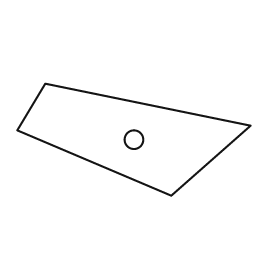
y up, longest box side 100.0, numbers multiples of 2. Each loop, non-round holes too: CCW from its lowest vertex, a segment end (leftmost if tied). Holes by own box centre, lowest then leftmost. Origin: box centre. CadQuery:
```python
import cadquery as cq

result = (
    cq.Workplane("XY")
    .moveTo(16.0, -24.0)
    .lineTo(50.0, 6.0)
    .lineTo(-38.0, 24.0)
    .lineTo(-50.0, 4.0)
    .close()
    .moveTo(0.0, 0.0)
    .circle(4.0)
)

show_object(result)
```